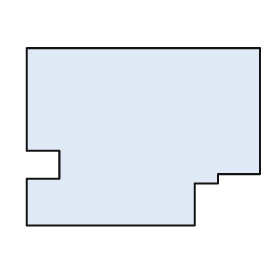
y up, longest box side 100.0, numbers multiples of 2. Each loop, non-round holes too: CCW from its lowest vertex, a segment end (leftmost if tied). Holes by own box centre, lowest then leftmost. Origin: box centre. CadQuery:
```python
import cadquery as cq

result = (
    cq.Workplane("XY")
    .moveTo(-50.0, -38.0)
    .lineTo(22.0, -38.0)
    .lineTo(22.0, -20.0)
    .lineTo(32.0, -20.0)
    .lineTo(32.0, -16.0)
    .lineTo(50.0, -16.0)
    .lineTo(50.0, 38.0)
    .lineTo(-50.0, 38.0)
    .lineTo(-50.0, -6.0)
    .lineTo(-36.0, -6.0)
    .lineTo(-36.0, -18.0)
    .lineTo(-50.0, -18.0)
    .close()
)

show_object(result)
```